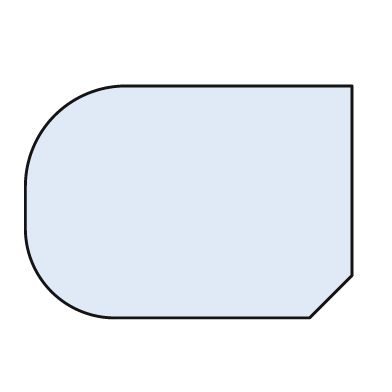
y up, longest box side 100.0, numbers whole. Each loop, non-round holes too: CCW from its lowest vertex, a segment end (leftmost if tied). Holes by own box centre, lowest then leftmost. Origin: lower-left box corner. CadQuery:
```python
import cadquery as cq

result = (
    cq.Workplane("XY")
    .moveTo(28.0, 0.0)
    .lineTo(87.0, 0.0)
    .lineTo(100.0, 13.0)
    .lineTo(100.0, 71.0)
    .lineTo(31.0, 71.0)
    .threePointArc((9.0, 62.0), (0.0, 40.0))
    .lineTo(0.0, 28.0)
    .threePointArc((8.0, 8.0), (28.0, 0.0))
    .close()
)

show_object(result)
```